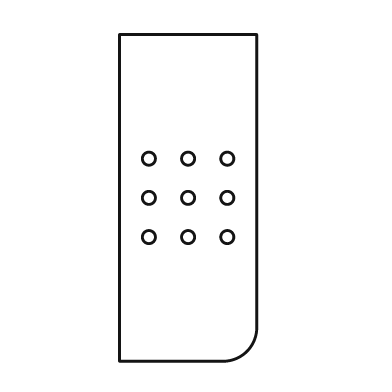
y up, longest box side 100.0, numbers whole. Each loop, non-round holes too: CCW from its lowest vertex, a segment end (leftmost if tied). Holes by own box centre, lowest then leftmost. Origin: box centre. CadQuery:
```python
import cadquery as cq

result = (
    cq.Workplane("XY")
    .moveTo(-21.0, -50.0)
    .lineTo(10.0, -50.0)
    .threePointArc((18.0, -47.0), (21.0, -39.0))
    .lineTo(21.0, 50.0)
    .lineTo(-21.0, 50.0)
    .close()
    .moveTo(-12.0, -12.0)
    .circle(2.0)
    .moveTo(0.0, -12.0)
    .circle(2.0)
    .moveTo(12.0, -12.0)
    .circle(2.0)
    .moveTo(-12.0, 0.0)
    .circle(2.0)
    .moveTo(0.0, 0.0)
    .circle(2.0)
    .moveTo(12.0, 0.0)
    .circle(2.0)
    .moveTo(-12.0, 12.0)
    .circle(2.0)
    .moveTo(0.0, 12.0)
    .circle(2.0)
    .moveTo(12.0, 12.0)
    .circle(2.0)
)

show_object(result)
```